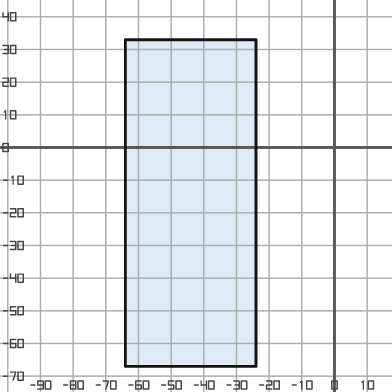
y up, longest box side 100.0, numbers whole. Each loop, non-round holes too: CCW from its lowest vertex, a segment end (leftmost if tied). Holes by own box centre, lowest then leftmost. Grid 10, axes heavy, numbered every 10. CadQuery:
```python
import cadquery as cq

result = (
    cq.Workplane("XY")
    .moveTo(-64.0, -67.0)
    .lineTo(-24.0, -67.0)
    .lineTo(-24.0, 33.0)
    .lineTo(-64.0, 33.0)
    .close()
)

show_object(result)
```